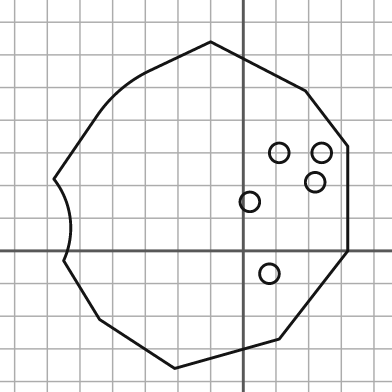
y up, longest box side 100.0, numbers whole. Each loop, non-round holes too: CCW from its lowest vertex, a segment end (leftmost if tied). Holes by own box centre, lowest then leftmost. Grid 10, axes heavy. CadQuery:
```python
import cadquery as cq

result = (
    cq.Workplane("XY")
    .moveTo(-21.0, -36.0)
    .lineTo(11.0, -27.0)
    .lineTo(32.0, 0.0)
    .lineTo(32.0, 32.0)
    .lineTo(19.0, 49.0)
    .lineTo(-10.0, 64.0)
    .lineTo(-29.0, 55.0)
    .threePointArc((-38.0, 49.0), (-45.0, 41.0))
    .lineTo(-58.0, 22.0)
    .threePointArc((-53.0, 10.0), (-55.0, -3.0))
    .lineTo(-44.0, -21.0)
    .close()
    .moveTo(8.0, -7.0)
    .circle(3.0)
    .moveTo(2.0, 15.0)
    .circle(3.0)
    .moveTo(22.0, 21.0)
    .circle(3.0)
    .moveTo(11.0, 30.0)
    .circle(3.0)
    .moveTo(24.0, 30.0)
    .circle(3.0)
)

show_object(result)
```